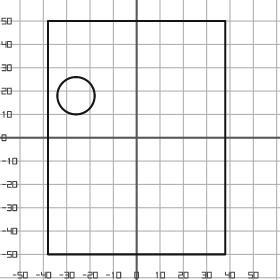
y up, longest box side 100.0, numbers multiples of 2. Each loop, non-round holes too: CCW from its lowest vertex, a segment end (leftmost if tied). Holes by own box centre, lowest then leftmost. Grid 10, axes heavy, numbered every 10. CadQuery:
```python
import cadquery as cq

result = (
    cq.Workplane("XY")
    .moveTo(-38.0, -50.0)
    .lineTo(38.0, -50.0)
    .lineTo(38.0, 50.0)
    .lineTo(-38.0, 50.0)
    .close()
    .moveTo(-26.0, 18.0)
    .circle(8.0)
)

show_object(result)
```